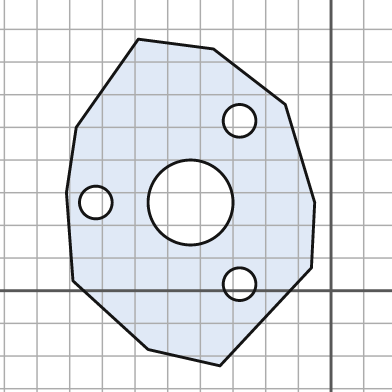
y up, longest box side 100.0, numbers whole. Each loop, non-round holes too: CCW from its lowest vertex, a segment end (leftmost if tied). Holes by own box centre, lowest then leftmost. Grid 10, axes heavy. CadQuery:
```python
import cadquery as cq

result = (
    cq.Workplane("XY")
    .moveTo(-34.0, -23.0)
    .lineTo(-6.0, 7.0)
    .lineTo(-5.0, 27.0)
    .lineTo(-14.0, 57.0)
    .lineTo(-36.0, 74.0)
    .lineTo(-59.0, 77.0)
    .lineTo(-78.0, 50.0)
    .lineTo(-81.0, 30.0)
    .lineTo(-79.0, 3.0)
    .lineTo(-56.0, -18.0)
    .close()
    .moveTo(-28.0, 2.0)
    .circle(5.0)
    .moveTo(-72.0, 27.0)
    .circle(5.0)
    .moveTo(-43.0, 27.0)
    .circle(13.0)
    .moveTo(-28.0, 52.0)
    .circle(5.0)
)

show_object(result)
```